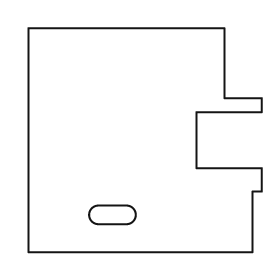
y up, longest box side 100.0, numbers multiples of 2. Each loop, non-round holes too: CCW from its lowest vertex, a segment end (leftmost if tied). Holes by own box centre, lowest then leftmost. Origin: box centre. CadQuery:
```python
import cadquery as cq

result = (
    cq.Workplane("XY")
    .moveTo(-50.0, -48.0)
    .lineTo(46.0, -48.0)
    .lineTo(46.0, -22.0)
    .lineTo(50.0, -22.0)
    .lineTo(50.0, -12.0)
    .lineTo(22.0, -12.0)
    .lineTo(22.0, 12.0)
    .lineTo(50.0, 12.0)
    .lineTo(50.0, 18.0)
    .lineTo(34.0, 18.0)
    .lineTo(34.0, 48.0)
    .lineTo(-50.0, 48.0)
    .close()
    .moveTo(-20.0, -36.0)
    .lineTo(-8.0, -36.0)
    .threePointArc((-4.0, -32.0), (-8.0, -28.0))
    .lineTo(-20.0, -28.0)
    .threePointArc((-24.0, -32.0), (-20.0, -36.0))
    .close()
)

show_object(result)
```